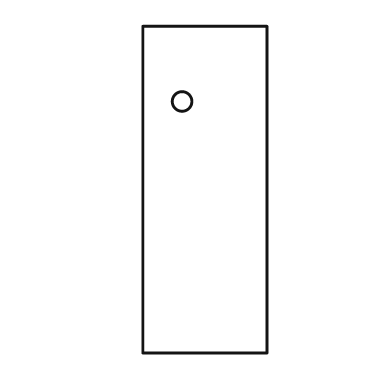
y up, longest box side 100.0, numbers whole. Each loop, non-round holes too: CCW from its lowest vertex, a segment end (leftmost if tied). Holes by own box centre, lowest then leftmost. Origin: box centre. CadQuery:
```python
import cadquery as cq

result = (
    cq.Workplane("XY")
    .moveTo(-19.0, -50.0)
    .lineTo(19.0, -50.0)
    .lineTo(19.0, 50.0)
    .lineTo(-19.0, 50.0)
    .close()
    .moveTo(-7.0, 27.0)
    .circle(3.0)
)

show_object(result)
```